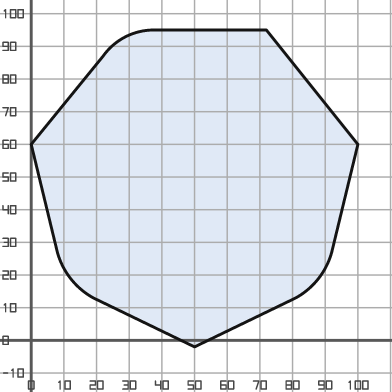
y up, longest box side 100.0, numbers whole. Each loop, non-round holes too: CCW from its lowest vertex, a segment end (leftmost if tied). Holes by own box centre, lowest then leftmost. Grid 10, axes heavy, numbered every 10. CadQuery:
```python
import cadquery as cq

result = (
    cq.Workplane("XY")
    .moveTo(50.0, -2.0)
    .lineTo(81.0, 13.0)
    .threePointArc((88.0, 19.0), (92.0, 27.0))
    .lineTo(100.0, 60.0)
    .lineTo(72.0, 95.0)
    .lineTo(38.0, 95.0)
    .threePointArc((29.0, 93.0), (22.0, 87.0))
    .lineTo(0.0, 60.0)
    .lineTo(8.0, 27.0)
    .threePointArc((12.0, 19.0), (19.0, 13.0))
    .close()
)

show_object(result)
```